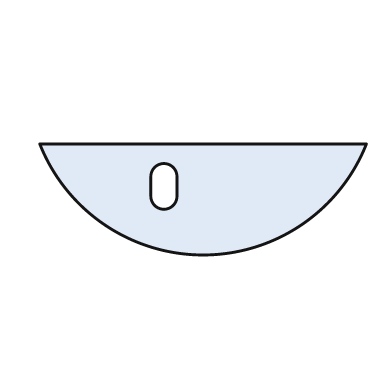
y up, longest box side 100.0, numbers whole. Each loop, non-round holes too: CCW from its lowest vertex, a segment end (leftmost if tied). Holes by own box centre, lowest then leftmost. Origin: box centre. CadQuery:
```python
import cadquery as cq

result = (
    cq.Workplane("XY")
    .moveTo(-50.0, 17.0)
    .threePointArc((0.0, -17.0), (50.0, 17.0))
    .close()
    .moveTo(-16.0, 1.0)
    .threePointArc((-12.0, -3.0), (-8.0, 1.0))
    .lineTo(-8.0, 7.0)
    .threePointArc((-12.0, 11.0), (-16.0, 7.0))
    .close()
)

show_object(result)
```